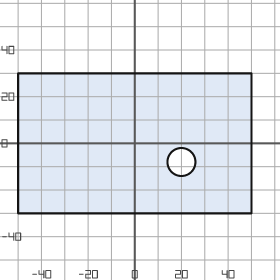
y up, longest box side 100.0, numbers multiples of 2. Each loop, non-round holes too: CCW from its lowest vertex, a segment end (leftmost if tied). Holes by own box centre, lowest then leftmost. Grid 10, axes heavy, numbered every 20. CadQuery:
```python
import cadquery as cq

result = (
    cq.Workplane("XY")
    .moveTo(-50.0, -30.0)
    .lineTo(50.0, -30.0)
    .lineTo(50.0, 30.0)
    .lineTo(-50.0, 30.0)
    .close()
    .moveTo(20.0, -8.0)
    .circle(6.0)
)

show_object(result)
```